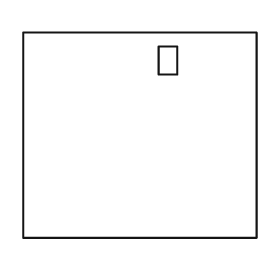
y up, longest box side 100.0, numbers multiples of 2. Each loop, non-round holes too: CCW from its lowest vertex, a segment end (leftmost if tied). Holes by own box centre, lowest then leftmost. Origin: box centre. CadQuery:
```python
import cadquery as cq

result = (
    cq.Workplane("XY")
    .moveTo(-50.0, -44.0)
    .lineTo(50.0, -44.0)
    .lineTo(50.0, 44.0)
    .lineTo(-50.0, 44.0)
    .close()
    .moveTo(8.0, 26.0)
    .lineTo(16.0, 26.0)
    .lineTo(16.0, 38.0)
    .lineTo(8.0, 38.0)
    .close()
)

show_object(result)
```